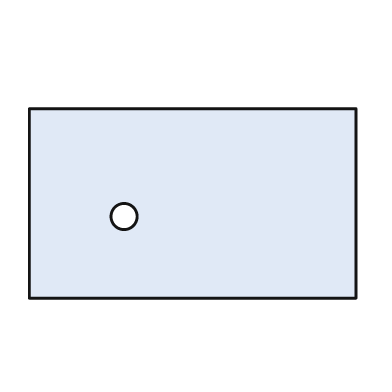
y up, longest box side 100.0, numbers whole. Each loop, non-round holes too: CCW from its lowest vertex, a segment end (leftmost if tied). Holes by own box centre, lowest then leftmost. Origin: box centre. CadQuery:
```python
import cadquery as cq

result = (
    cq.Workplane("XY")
    .moveTo(-50.0, -29.0)
    .lineTo(50.0, -29.0)
    .lineTo(50.0, 29.0)
    .lineTo(-50.0, 29.0)
    .close()
    .moveTo(-21.0, -4.0)
    .circle(4.0)
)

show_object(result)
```